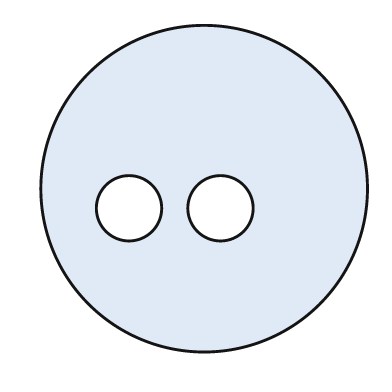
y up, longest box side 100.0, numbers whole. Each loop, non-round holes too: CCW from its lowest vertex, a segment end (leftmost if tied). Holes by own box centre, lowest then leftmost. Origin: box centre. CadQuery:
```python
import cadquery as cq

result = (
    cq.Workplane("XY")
    .moveTo(0.0, 0.0)
    .circle(50.0)
    .moveTo(-23.0, -6.0)
    .circle(10.0)
    .moveTo(5.0, -6.0)
    .circle(10.0)
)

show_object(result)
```